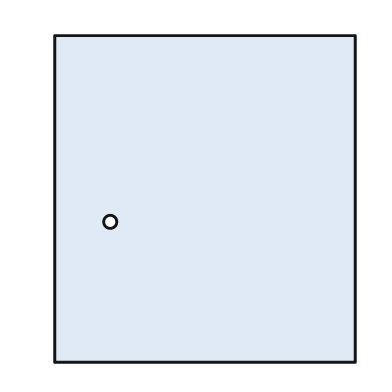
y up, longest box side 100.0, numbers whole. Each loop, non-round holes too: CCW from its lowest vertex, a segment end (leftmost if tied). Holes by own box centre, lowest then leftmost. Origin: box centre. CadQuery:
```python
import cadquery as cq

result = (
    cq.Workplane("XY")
    .moveTo(-46.0, -50.0)
    .lineTo(46.0, -50.0)
    .lineTo(46.0, 50.0)
    .lineTo(-46.0, 50.0)
    .close()
    .moveTo(-29.0, -7.0)
    .circle(2.0)
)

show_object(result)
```